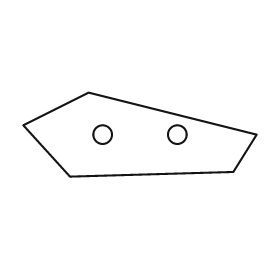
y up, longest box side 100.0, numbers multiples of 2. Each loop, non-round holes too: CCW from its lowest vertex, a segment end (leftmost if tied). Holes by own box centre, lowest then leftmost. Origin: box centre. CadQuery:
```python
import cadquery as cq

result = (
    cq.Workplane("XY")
    .moveTo(-30.0, -18.0)
    .lineTo(40.0, -16.0)
    .lineTo(50.0, 0.0)
    .lineTo(-22.0, 18.0)
    .lineTo(-50.0, 4.0)
    .close()
    .moveTo(-16.0, 0.0)
    .circle(4.0)
    .moveTo(16.0, 0.0)
    .circle(4.0)
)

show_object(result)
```